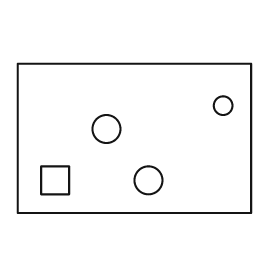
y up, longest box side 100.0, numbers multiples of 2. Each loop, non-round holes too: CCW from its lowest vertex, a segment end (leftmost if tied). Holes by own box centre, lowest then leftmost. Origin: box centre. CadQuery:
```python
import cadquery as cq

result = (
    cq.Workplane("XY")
    .moveTo(-50.0, -32.0)
    .lineTo(50.0, -32.0)
    .lineTo(50.0, 32.0)
    .lineTo(-50.0, 32.0)
    .close()
    .moveTo(-40.0, -24.0)
    .lineTo(-28.0, -24.0)
    .lineTo(-28.0, -12.0)
    .lineTo(-40.0, -12.0)
    .close()
    .moveTo(6.0, -18.0)
    .circle(6.0)
    .moveTo(-12.0, 4.0)
    .circle(6.0)
    .moveTo(38.0, 14.0)
    .circle(4.0)
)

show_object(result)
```